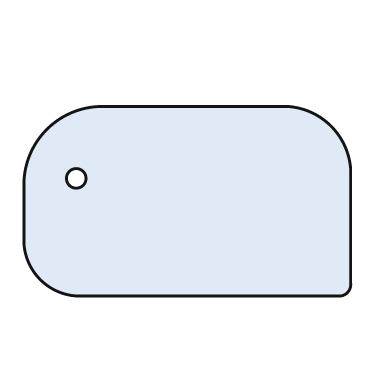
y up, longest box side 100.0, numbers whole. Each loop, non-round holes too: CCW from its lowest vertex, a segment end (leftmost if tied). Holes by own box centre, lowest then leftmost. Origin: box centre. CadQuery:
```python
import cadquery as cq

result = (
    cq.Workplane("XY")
    .moveTo(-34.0, -29.0)
    .lineTo(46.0, -29.0)
    .threePointArc((49.0, -28.0), (50.0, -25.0))
    .lineTo(50.0, 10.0)
    .threePointArc((44.0, 23.0), (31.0, 29.0))
    .lineTo(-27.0, 29.0)
    .threePointArc((-43.0, 22.0), (-50.0, 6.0))
    .lineTo(-50.0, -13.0)
    .threePointArc((-45.0, -24.0), (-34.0, -29.0))
    .close()
    .moveTo(-34.0, 7.0)
    .circle(3.0)
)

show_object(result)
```